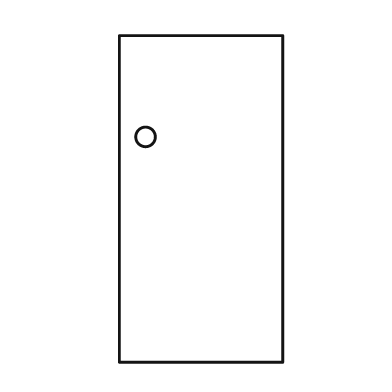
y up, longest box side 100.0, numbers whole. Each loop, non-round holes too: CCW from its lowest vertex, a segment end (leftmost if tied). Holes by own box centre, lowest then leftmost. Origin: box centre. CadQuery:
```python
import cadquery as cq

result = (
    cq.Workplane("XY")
    .moveTo(-25.0, -50.0)
    .lineTo(25.0, -50.0)
    .lineTo(25.0, 50.0)
    .lineTo(-25.0, 50.0)
    .close()
    .moveTo(-17.0, 19.0)
    .circle(3.0)
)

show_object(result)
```